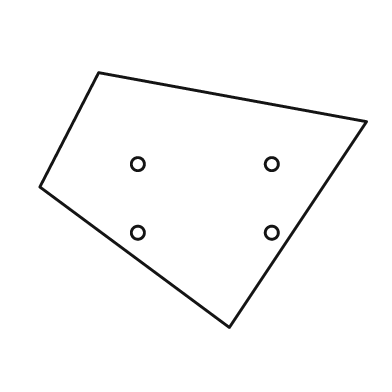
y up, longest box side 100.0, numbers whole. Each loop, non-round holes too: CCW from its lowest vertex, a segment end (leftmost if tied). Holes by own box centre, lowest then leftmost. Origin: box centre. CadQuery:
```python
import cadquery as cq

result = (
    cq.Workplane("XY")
    .moveTo(8.0, -39.0)
    .lineTo(50.0, 24.0)
    .lineTo(-32.0, 39.0)
    .lineTo(-50.0, 4.0)
    .close()
    .moveTo(-20.0, -10.0)
    .circle(2.0)
    .moveTo(21.0, -10.0)
    .circle(2.0)
    .moveTo(-20.0, 11.0)
    .circle(2.0)
    .moveTo(21.0, 11.0)
    .circle(2.0)
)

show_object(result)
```